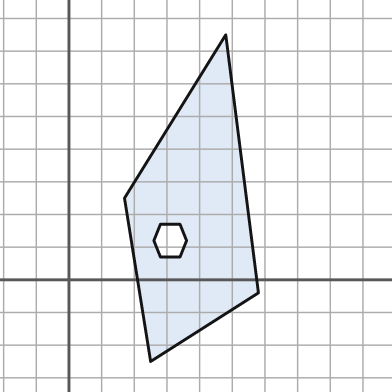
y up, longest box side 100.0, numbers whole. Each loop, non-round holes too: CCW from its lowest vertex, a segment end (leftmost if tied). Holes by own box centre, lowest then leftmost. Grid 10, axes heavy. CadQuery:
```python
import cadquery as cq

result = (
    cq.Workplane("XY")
    .moveTo(25.0, -25.0)
    .lineTo(58.0, -4.0)
    .lineTo(48.0, 75.0)
    .lineTo(17.0, 25.0)
    .close()
    .moveTo(28.0, 7.0)
    .lineTo(34.0, 7.0)
    .lineTo(36.0, 12.0)
    .lineTo(34.0, 17.0)
    .lineTo(28.0, 17.0)
    .lineTo(26.0, 12.0)
    .close()
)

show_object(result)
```